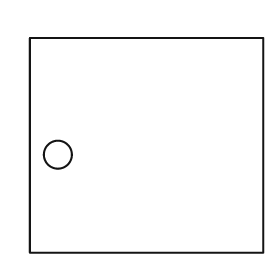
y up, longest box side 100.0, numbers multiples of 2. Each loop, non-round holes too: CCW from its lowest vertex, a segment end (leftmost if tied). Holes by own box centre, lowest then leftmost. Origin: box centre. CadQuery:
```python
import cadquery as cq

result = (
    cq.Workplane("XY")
    .moveTo(-50.0, -46.0)
    .lineTo(50.0, -46.0)
    .lineTo(50.0, 46.0)
    .lineTo(-50.0, 46.0)
    .close()
    .moveTo(-38.0, -4.0)
    .circle(6.0)
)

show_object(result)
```